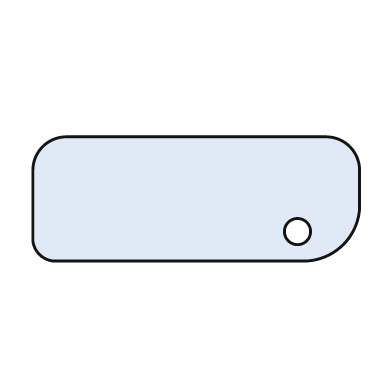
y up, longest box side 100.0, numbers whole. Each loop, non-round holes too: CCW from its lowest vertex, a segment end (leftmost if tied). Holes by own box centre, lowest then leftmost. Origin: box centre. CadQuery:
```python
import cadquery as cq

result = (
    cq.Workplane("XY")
    .moveTo(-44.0, -19.0)
    .lineTo(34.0, -19.0)
    .threePointArc((45.0, -14.0), (50.0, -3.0))
    .lineTo(50.0, 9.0)
    .threePointArc((47.0, 16.0), (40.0, 19.0))
    .lineTo(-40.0, 19.0)
    .threePointArc((-47.0, 16.0), (-50.0, 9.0))
    .lineTo(-50.0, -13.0)
    .threePointArc((-48.0, -17.0), (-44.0, -19.0))
    .close()
    .moveTo(31.0, -10.0)
    .circle(4.0)
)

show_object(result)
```